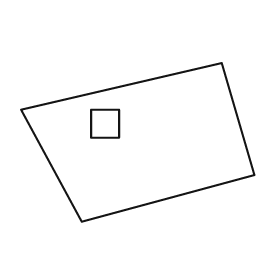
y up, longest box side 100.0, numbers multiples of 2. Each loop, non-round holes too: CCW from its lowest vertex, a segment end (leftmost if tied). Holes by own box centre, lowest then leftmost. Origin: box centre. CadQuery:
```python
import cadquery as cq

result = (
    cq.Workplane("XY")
    .moveTo(-24.0, -34.0)
    .lineTo(50.0, -14.0)
    .lineTo(36.0, 34.0)
    .lineTo(-50.0, 14.0)
    .close()
    .moveTo(-20.0, 2.0)
    .lineTo(-8.0, 2.0)
    .lineTo(-8.0, 14.0)
    .lineTo(-20.0, 14.0)
    .close()
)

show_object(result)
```